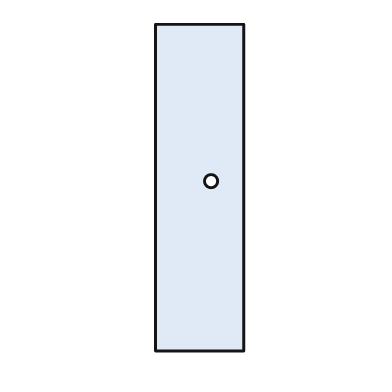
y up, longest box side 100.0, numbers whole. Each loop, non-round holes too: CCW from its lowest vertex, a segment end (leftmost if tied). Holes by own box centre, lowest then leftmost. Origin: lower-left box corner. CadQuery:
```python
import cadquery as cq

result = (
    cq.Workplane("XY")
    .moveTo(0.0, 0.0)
    .lineTo(27.0, 0.0)
    .lineTo(27.0, 100.0)
    .lineTo(0.0, 100.0)
    .close()
    .moveTo(17.0, 52.0)
    .circle(2.0)
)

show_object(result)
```